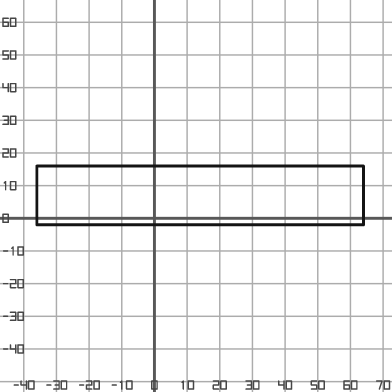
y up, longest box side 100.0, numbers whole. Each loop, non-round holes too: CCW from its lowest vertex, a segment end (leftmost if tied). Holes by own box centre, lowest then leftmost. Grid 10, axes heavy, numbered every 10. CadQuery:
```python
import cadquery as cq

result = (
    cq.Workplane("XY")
    .moveTo(-36.0, -2.0)
    .lineTo(64.0, -2.0)
    .lineTo(64.0, 16.0)
    .lineTo(-36.0, 16.0)
    .close()
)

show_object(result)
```